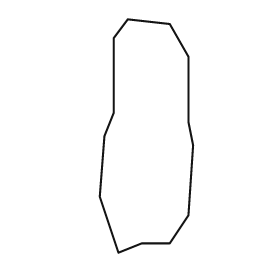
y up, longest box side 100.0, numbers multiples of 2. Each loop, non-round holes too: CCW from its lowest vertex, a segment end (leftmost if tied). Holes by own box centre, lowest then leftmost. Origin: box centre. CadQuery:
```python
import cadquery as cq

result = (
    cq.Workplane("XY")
    .moveTo(-12.0, -50.0)
    .lineTo(-2.0, -46.0)
    .lineTo(10.0, -46.0)
    .lineTo(18.0, -34.0)
    .lineTo(20.0, -4.0)
    .lineTo(18.0, 6.0)
    .lineTo(18.0, 34.0)
    .lineTo(10.0, 48.0)
    .lineTo(-8.0, 50.0)
    .lineTo(-14.0, 42.0)
    .lineTo(-14.0, 10.0)
    .lineTo(-18.0, 0.0)
    .lineTo(-20.0, -26.0)
    .close()
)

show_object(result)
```